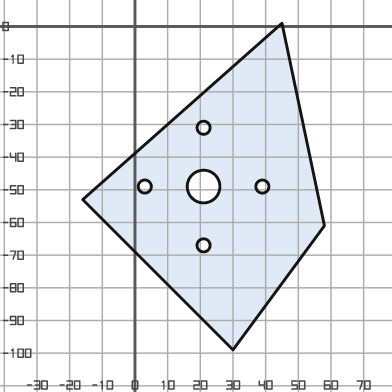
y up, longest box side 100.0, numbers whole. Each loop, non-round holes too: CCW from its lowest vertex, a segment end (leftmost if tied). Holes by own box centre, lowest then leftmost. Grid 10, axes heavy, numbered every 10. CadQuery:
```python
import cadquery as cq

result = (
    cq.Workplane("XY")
    .moveTo(30.0, -99.0)
    .lineTo(58.0, -61.0)
    .lineTo(45.0, 1.0)
    .lineTo(-16.0, -53.0)
    .close()
    .moveTo(21.0, -67.0)
    .circle(2.0)
    .moveTo(3.0, -49.0)
    .circle(2.0)
    .moveTo(21.0, -49.0)
    .circle(5.0)
    .moveTo(39.0, -49.0)
    .circle(2.0)
    .moveTo(21.0, -31.0)
    .circle(2.0)
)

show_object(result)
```